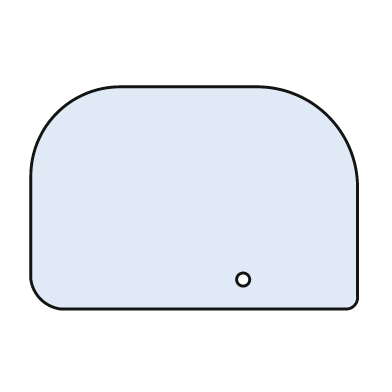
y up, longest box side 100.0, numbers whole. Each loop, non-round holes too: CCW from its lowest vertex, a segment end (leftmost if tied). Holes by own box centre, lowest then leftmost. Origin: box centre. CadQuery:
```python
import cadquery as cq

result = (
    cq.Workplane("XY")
    .moveTo(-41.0, -34.0)
    .lineTo(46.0, -34.0)
    .threePointArc((49.0, -33.0), (50.0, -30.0))
    .lineTo(50.0, 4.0)
    .threePointArc((41.0, 25.0), (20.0, 34.0))
    .lineTo(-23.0, 34.0)
    .threePointArc((-42.0, 26.0), (-50.0, 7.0))
    .lineTo(-50.0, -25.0)
    .threePointArc((-47.0, -31.0), (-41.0, -34.0))
    .close()
    .moveTo(15.0, -25.0)
    .circle(2.0)
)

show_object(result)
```